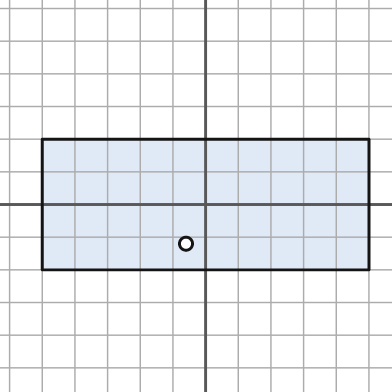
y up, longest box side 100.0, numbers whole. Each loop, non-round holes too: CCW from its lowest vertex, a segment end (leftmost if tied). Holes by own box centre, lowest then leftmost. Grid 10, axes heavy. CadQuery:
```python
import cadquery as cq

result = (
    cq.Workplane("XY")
    .moveTo(-50.0, -20.0)
    .lineTo(50.0, -20.0)
    .lineTo(50.0, 20.0)
    .lineTo(-50.0, 20.0)
    .close()
    .moveTo(-6.0, -12.0)
    .circle(2.0)
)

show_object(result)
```